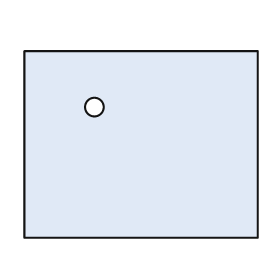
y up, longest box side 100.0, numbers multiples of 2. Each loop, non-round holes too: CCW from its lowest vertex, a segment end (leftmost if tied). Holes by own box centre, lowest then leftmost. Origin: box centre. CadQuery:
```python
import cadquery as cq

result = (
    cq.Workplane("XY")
    .moveTo(-50.0, -40.0)
    .lineTo(50.0, -40.0)
    .lineTo(50.0, 40.0)
    .lineTo(-50.0, 40.0)
    .close()
    .moveTo(-20.0, 16.0)
    .circle(4.0)
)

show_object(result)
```